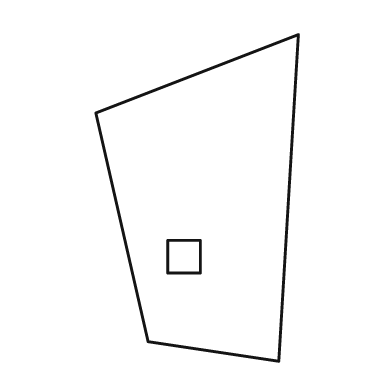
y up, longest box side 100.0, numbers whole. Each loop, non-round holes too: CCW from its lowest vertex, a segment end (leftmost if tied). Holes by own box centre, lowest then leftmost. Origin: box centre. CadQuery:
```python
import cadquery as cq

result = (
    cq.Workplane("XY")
    .moveTo(25.0, -50.0)
    .lineTo(31.0, 50.0)
    .lineTo(-31.0, 26.0)
    .lineTo(-15.0, -44.0)
    .close()
    .moveTo(-9.0, -23.0)
    .lineTo(1.0, -23.0)
    .lineTo(1.0, -13.0)
    .lineTo(-9.0, -13.0)
    .close()
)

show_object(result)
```